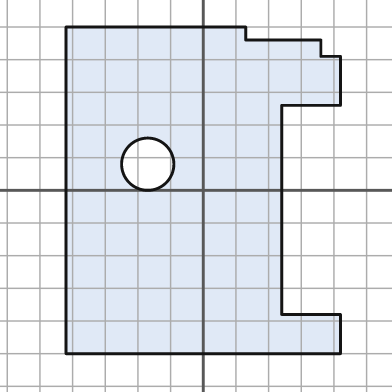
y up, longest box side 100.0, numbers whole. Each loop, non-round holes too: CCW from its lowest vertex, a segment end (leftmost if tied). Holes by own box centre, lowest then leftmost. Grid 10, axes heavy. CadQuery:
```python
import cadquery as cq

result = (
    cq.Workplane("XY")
    .moveTo(-42.0, -50.0)
    .lineTo(42.0, -50.0)
    .lineTo(42.0, -38.0)
    .lineTo(24.0, -38.0)
    .lineTo(24.0, 26.0)
    .lineTo(42.0, 26.0)
    .lineTo(42.0, 41.0)
    .lineTo(36.0, 41.0)
    .lineTo(36.0, 46.0)
    .lineTo(13.0, 46.0)
    .lineTo(13.0, 50.0)
    .lineTo(-42.0, 50.0)
    .close()
    .moveTo(-17.0, 8.0)
    .circle(8.0)
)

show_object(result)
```